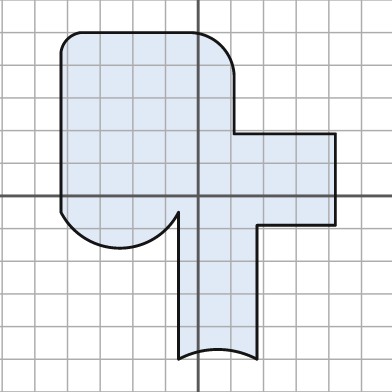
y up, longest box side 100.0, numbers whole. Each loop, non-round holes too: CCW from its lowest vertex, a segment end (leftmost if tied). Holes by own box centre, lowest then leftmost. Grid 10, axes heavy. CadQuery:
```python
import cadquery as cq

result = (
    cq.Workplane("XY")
    .moveTo(-6.0, -50.0)
    .threePointArc((6.0, -47.0), (18.0, -50.0))
    .lineTo(18.0, -9.0)
    .lineTo(42.0, -9.0)
    .lineTo(42.0, 19.0)
    .lineTo(11.0, 19.0)
    .lineTo(11.0, 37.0)
    .threePointArc((7.0, 46.0), (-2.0, 50.0))
    .lineTo(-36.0, 50.0)
    .threePointArc((-40.0, 48.0), (-42.0, 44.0))
    .lineTo(-42.0, -5.0)
    .threePointArc((-24.0, -16.0), (-6.0, -5.0))
    .close()
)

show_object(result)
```